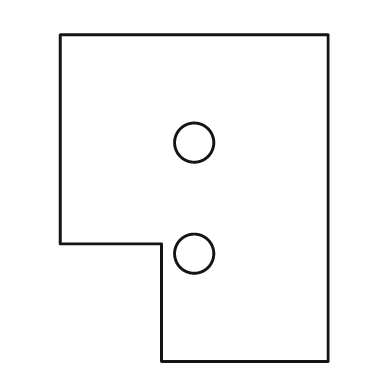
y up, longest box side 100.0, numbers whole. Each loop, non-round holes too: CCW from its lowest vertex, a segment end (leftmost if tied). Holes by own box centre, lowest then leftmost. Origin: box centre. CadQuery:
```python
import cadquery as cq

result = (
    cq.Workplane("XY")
    .moveTo(-10.0, -50.0)
    .lineTo(41.0, -50.0)
    .lineTo(41.0, 50.0)
    .lineTo(-41.0, 50.0)
    .lineTo(-41.0, -14.0)
    .lineTo(-10.0, -14.0)
    .close()
    .moveTo(0.0, -17.0)
    .circle(6.0)
    .moveTo(0.0, 17.0)
    .circle(6.0)
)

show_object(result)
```